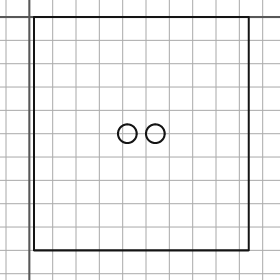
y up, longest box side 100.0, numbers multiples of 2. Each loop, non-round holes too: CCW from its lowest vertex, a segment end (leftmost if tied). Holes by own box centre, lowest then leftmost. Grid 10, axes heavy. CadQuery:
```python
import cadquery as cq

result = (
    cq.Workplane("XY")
    .moveTo(2.0, -100.0)
    .lineTo(94.0, -100.0)
    .lineTo(94.0, 0.0)
    .lineTo(2.0, 0.0)
    .close()
    .moveTo(42.0, -50.0)
    .circle(4.0)
    .moveTo(54.0, -50.0)
    .circle(4.0)
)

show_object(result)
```